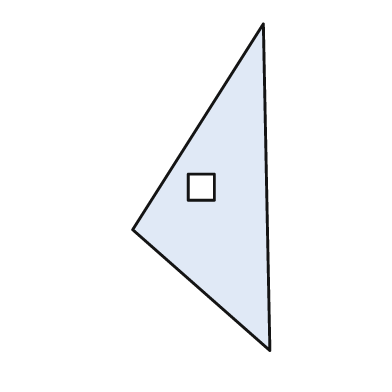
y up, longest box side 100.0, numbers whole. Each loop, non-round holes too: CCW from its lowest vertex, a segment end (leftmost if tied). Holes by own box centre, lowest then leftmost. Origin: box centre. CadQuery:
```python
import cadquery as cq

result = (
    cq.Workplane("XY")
    .moveTo(21.0, -50.0)
    .lineTo(19.0, 50.0)
    .lineTo(-21.0, -13.0)
    .close()
    .moveTo(-4.0, -4.0)
    .lineTo(4.0, -4.0)
    .lineTo(4.0, 4.0)
    .lineTo(-4.0, 4.0)
    .close()
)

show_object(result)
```